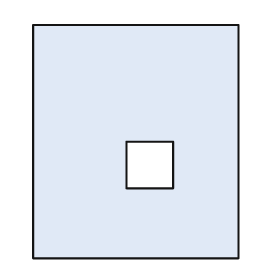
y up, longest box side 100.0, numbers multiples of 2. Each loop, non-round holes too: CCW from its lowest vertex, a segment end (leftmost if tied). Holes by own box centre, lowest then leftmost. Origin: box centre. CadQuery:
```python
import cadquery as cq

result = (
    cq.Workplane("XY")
    .moveTo(-44.0, -50.0)
    .lineTo(44.0, -50.0)
    .lineTo(44.0, 50.0)
    .lineTo(-44.0, 50.0)
    .close()
    .moveTo(-4.0, -20.0)
    .lineTo(16.0, -20.0)
    .lineTo(16.0, 0.0)
    .lineTo(-4.0, 0.0)
    .close()
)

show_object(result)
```